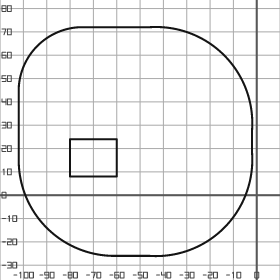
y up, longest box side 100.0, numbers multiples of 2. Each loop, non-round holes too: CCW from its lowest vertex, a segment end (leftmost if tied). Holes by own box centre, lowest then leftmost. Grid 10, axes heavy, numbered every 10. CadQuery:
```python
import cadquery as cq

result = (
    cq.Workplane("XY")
    .moveTo(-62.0, -26.0)
    .lineTo(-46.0, -26.0)
    .threePointArc((-14.0, -14.0), (-2.0, 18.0))
    .lineTo(-2.0, 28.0)
    .threePointArc((-14.0, 60.0), (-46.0, 72.0))
    .lineTo(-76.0, 72.0)
    .threePointArc((-94.0, 64.0), (-102.0, 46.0))
    .lineTo(-102.0, 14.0)
    .threePointArc((-90.0, -14.0), (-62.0, -26.0))
    .close()
    .moveTo(-80.0, 8.0)
    .lineTo(-60.0, 8.0)
    .lineTo(-60.0, 24.0)
    .lineTo(-80.0, 24.0)
    .close()
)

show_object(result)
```